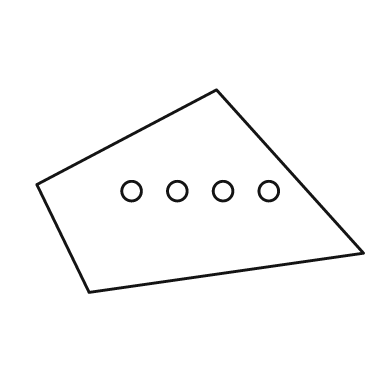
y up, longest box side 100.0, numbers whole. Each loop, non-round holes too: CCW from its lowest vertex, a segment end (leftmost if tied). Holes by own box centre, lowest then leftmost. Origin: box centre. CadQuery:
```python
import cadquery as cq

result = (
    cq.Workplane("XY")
    .moveTo(-34.0, -31.0)
    .lineTo(50.0, -19.0)
    .lineTo(5.0, 31.0)
    .lineTo(-50.0, 2.0)
    .close()
    .moveTo(-21.0, 0.0)
    .circle(3.0)
    .moveTo(-7.0, 0.0)
    .circle(3.0)
    .moveTo(7.0, 0.0)
    .circle(3.0)
    .moveTo(21.0, 0.0)
    .circle(3.0)
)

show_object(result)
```